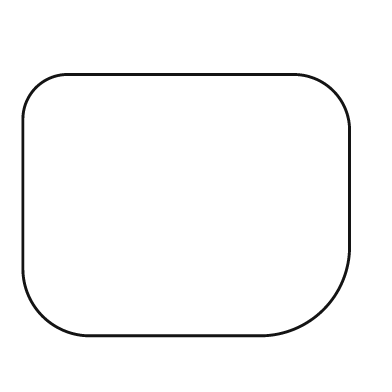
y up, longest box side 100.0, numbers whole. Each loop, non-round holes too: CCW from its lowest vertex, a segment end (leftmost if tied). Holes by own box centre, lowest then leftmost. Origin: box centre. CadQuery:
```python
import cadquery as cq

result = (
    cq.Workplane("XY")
    .moveTo(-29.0, -40.0)
    .lineTo(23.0, -40.0)
    .threePointArc((42.0, -32.0), (50.0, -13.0))
    .lineTo(50.0, 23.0)
    .threePointArc((45.0, 35.0), (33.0, 40.0))
    .lineTo(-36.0, 40.0)
    .threePointArc((-46.0, 36.0), (-50.0, 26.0))
    .lineTo(-50.0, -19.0)
    .threePointArc((-44.0, -34.0), (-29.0, -40.0))
    .close()
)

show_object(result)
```